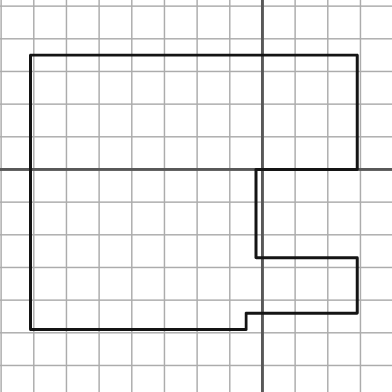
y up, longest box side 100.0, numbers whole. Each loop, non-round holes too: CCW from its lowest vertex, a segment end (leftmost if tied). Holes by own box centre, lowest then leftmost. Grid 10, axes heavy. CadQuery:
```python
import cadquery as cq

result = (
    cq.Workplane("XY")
    .moveTo(-71.0, -49.0)
    .lineTo(-5.0, -49.0)
    .lineTo(-5.0, -44.0)
    .lineTo(29.0, -44.0)
    .lineTo(29.0, -27.0)
    .lineTo(-2.0, -27.0)
    .lineTo(-2.0, 0.0)
    .lineTo(29.0, 0.0)
    .lineTo(29.0, 35.0)
    .lineTo(-71.0, 35.0)
    .close()
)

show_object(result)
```